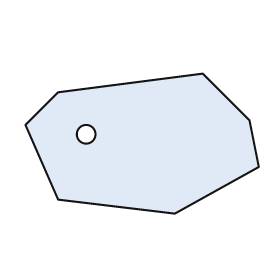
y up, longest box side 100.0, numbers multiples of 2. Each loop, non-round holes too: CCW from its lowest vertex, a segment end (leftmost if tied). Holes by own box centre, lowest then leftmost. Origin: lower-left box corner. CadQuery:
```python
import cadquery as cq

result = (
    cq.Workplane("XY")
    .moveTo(64.0, 0.0)
    .lineTo(100.0, 20.0)
    .lineTo(96.0, 40.0)
    .lineTo(76.0, 60.0)
    .lineTo(14.0, 52.0)
    .lineTo(0.0, 38.0)
    .lineTo(14.0, 6.0)
    .close()
    .moveTo(26.0, 34.0)
    .circle(4.0)
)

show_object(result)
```